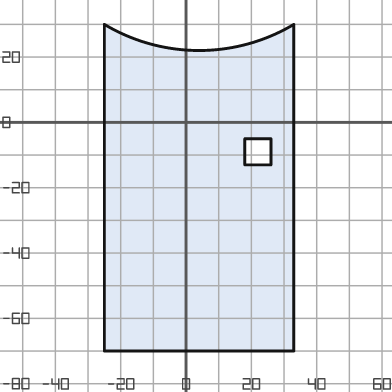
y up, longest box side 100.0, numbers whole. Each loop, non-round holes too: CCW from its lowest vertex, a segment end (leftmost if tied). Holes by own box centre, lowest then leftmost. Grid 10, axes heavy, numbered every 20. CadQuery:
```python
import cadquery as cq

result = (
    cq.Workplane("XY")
    .moveTo(-25.0, -70.0)
    .lineTo(33.0, -70.0)
    .lineTo(33.0, 30.0)
    .threePointArc((4.0, 22.0), (-25.0, 30.0))
    .close()
    .moveTo(18.0, -13.0)
    .lineTo(26.0, -13.0)
    .lineTo(26.0, -5.0)
    .lineTo(18.0, -5.0)
    .close()
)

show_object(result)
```